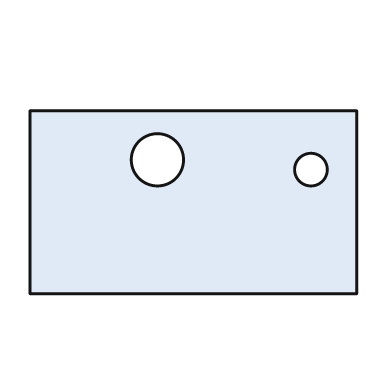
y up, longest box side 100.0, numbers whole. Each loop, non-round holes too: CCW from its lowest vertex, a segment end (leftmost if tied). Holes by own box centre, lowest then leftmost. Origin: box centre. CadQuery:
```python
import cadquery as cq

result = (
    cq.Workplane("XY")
    .moveTo(-50.0, -28.0)
    .lineTo(50.0, -28.0)
    .lineTo(50.0, 28.0)
    .lineTo(-50.0, 28.0)
    .close()
    .moveTo(36.0, 10.0)
    .circle(5.0)
    .moveTo(-11.0, 13.0)
    .circle(8.0)
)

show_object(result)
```